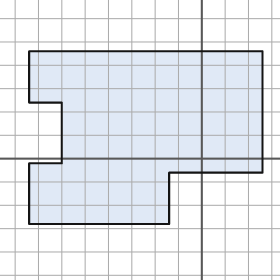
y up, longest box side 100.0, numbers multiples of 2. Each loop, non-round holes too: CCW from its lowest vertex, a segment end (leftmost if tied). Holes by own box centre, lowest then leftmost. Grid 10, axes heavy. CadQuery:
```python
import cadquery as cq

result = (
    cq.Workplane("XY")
    .moveTo(-74.0, -28.0)
    .lineTo(-14.0, -28.0)
    .lineTo(-14.0, -6.0)
    .lineTo(26.0, -6.0)
    .lineTo(26.0, 46.0)
    .lineTo(-74.0, 46.0)
    .lineTo(-74.0, 24.0)
    .lineTo(-60.0, 24.0)
    .lineTo(-60.0, -2.0)
    .lineTo(-74.0, -2.0)
    .close()
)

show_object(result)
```